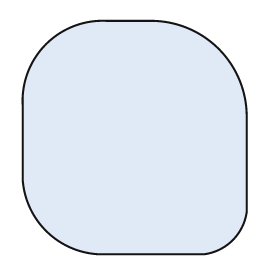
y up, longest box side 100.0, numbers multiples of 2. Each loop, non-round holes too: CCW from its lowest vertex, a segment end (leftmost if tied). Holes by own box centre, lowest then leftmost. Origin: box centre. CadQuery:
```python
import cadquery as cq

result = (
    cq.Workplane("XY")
    .moveTo(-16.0, -50.0)
    .lineTo(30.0, -50.0)
    .threePointArc((42.0, -44.0), (48.0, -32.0))
    .lineTo(48.0, 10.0)
    .threePointArc((36.0, 38.0), (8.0, 50.0))
    .lineTo(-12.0, 50.0)
    .threePointArc((-38.0, 40.0), (-48.0, 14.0))
    .lineTo(-48.0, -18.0)
    .threePointArc((-38.0, -40.0), (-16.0, -50.0))
    .close()
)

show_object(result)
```